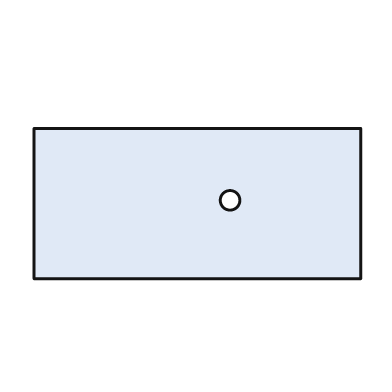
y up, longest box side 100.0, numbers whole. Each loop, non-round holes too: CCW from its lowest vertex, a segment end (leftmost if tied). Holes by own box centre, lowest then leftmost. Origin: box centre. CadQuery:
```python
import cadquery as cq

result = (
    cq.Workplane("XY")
    .moveTo(-50.0, -23.0)
    .lineTo(50.0, -23.0)
    .lineTo(50.0, 23.0)
    .lineTo(-50.0, 23.0)
    .close()
    .moveTo(10.0, 1.0)
    .circle(3.0)
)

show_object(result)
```